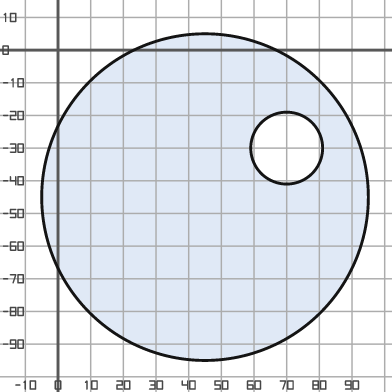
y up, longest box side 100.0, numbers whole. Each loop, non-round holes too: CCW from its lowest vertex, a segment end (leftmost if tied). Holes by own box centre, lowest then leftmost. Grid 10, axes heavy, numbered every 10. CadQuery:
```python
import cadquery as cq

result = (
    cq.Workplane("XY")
    .moveTo(45.0, -45.0)
    .circle(50.0)
    .moveTo(70.0, -30.0)
    .circle(11.0)
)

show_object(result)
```